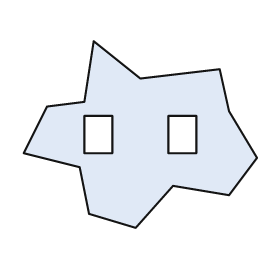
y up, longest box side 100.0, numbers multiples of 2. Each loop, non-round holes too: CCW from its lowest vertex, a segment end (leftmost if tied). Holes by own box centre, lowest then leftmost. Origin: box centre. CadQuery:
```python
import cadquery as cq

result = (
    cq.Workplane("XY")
    .moveTo(-2.0, -40.0)
    .lineTo(14.0, -22.0)
    .lineTo(38.0, -26.0)
    .lineTo(50.0, -10.0)
    .lineTo(38.0, 10.0)
    .lineTo(34.0, 28.0)
    .lineTo(0.0, 24.0)
    .lineTo(-20.0, 40.0)
    .lineTo(-24.0, 14.0)
    .lineTo(-40.0, 12.0)
    .lineTo(-50.0, -8.0)
    .lineTo(-26.0, -14.0)
    .lineTo(-22.0, -34.0)
    .close()
    .moveTo(-24.0, -8.0)
    .lineTo(-12.0, -8.0)
    .lineTo(-12.0, 8.0)
    .lineTo(-24.0, 8.0)
    .close()
    .moveTo(12.0, -8.0)
    .lineTo(24.0, -8.0)
    .lineTo(24.0, 8.0)
    .lineTo(12.0, 8.0)
    .close()
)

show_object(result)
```